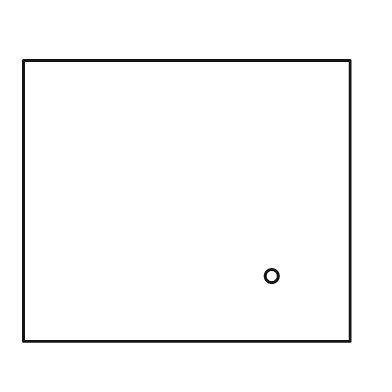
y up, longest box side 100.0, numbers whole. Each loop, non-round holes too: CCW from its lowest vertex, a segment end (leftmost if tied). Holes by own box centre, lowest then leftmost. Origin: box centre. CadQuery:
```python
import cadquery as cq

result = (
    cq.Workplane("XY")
    .moveTo(-50.0, -43.0)
    .lineTo(50.0, -43.0)
    .lineTo(50.0, 43.0)
    .lineTo(-50.0, 43.0)
    .close()
    .moveTo(26.0, -23.0)
    .circle(2.0)
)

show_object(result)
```